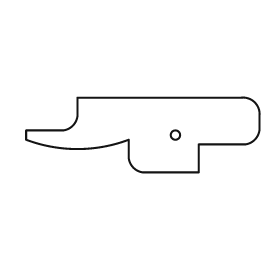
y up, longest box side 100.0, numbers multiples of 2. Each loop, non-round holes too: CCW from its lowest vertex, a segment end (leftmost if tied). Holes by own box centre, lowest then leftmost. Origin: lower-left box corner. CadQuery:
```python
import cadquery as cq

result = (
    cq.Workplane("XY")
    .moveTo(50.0, 0.0)
    .lineTo(74.0, 0.0)
    .lineTo(74.0, 12.0)
    .lineTo(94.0, 12.0)
    .threePointArc((98.0, 14.0), (100.0, 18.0))
    .lineTo(100.0, 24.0)
    .threePointArc((98.0, 30.0), (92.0, 32.0))
    .lineTo(22.0, 32.0)
    .lineTo(22.0, 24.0)
    .threePointArc((20.0, 20.0), (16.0, 18.0))
    .lineTo(0.0, 18.0)
    .lineTo(0.0, 14.0)
    .threePointArc((22.0, 10.0), (44.0, 14.0))
    .lineTo(44.0, 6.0)
    .threePointArc((46.0, 2.0), (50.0, 0.0))
    .close()
    .moveTo(64.0, 16.0)
    .circle(2.0)
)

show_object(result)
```